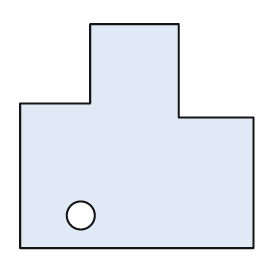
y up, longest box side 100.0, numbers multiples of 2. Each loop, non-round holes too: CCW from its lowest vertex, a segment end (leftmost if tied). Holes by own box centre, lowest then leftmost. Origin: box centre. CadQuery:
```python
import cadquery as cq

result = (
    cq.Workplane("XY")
    .moveTo(-50.0, -48.0)
    .lineTo(50.0, -48.0)
    .lineTo(50.0, 8.0)
    .lineTo(18.0, 8.0)
    .lineTo(18.0, 48.0)
    .lineTo(-20.0, 48.0)
    .lineTo(-20.0, 14.0)
    .lineTo(-50.0, 14.0)
    .close()
    .moveTo(-24.0, -34.0)
    .circle(6.0)
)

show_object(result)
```